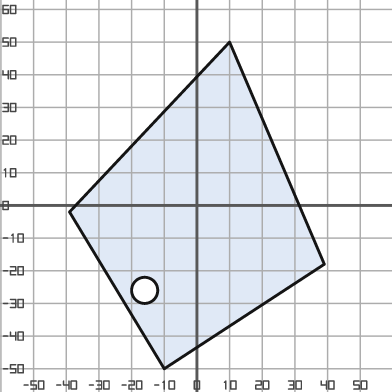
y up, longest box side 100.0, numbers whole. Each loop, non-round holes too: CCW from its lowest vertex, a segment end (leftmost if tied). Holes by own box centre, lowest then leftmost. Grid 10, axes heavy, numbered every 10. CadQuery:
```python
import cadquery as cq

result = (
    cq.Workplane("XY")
    .moveTo(-10.0, -50.0)
    .lineTo(39.0, -18.0)
    .lineTo(10.0, 50.0)
    .lineTo(-39.0, -2.0)
    .close()
    .moveTo(-16.0, -26.0)
    .circle(4.0)
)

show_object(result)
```